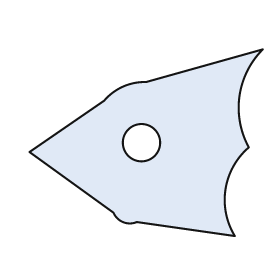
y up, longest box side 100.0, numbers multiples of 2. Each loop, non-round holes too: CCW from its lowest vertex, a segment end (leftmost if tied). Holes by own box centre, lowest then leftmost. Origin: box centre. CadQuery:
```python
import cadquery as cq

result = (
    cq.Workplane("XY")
    .moveTo(38.0, -40.0)
    .threePointArc((34.0, -20.0), (44.0, -2.0))
    .threePointArc((40.0, 20.0), (50.0, 40.0))
    .lineTo(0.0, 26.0)
    .threePointArc((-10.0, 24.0), (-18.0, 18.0))
    .lineTo(-50.0, -4.0)
    .lineTo(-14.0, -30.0)
    .threePointArc((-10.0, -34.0), (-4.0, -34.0))
    .close()
    .moveTo(-2.0, 0.0)
    .circle(8.0)
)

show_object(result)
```